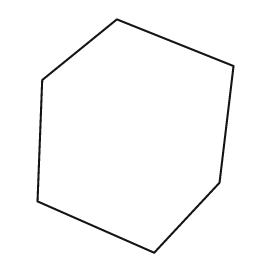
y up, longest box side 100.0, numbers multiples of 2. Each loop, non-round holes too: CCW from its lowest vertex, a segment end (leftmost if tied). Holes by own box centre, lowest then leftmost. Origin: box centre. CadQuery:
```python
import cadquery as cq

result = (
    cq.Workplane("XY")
    .moveTo(8.0, -50.0)
    .lineTo(36.0, -20.0)
    .lineTo(42.0, 30.0)
    .lineTo(-8.0, 50.0)
    .lineTo(-40.0, 24.0)
    .lineTo(-42.0, -28.0)
    .close()
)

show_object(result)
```